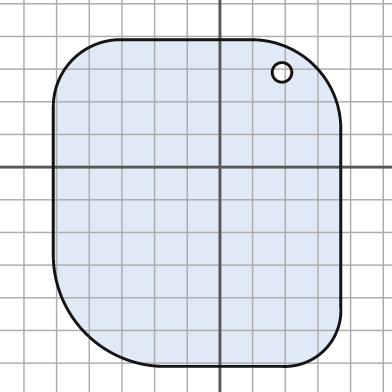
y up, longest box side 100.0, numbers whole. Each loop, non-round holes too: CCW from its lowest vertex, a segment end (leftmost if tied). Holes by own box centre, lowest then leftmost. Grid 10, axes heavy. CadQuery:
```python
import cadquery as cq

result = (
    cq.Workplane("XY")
    .moveTo(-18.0, -61.0)
    .lineTo(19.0, -61.0)
    .threePointArc((32.0, -56.0), (37.0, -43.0))
    .lineTo(37.0, 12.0)
    .threePointArc((29.0, 31.0), (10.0, 39.0))
    .lineTo(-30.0, 39.0)
    .threePointArc((-45.0, 33.0), (-51.0, 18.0))
    .lineTo(-51.0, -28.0)
    .threePointArc((-41.0, -51.0), (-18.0, -61.0))
    .close()
    .moveTo(19.0, 29.0)
    .circle(3.0)
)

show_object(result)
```